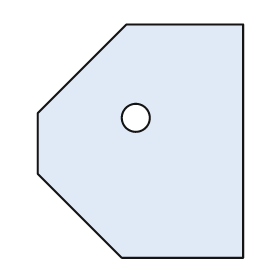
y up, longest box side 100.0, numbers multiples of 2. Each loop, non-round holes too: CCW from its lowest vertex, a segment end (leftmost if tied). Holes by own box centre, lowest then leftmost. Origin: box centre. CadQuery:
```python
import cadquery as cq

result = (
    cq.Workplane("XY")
    .moveTo(-8.0, -50.0)
    .lineTo(44.0, -50.0)
    .lineTo(44.0, 50.0)
    .lineTo(-6.0, 50.0)
    .lineTo(-44.0, 12.0)
    .lineTo(-44.0, -14.0)
    .close()
    .moveTo(-2.0, 10.0)
    .circle(6.0)
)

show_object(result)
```